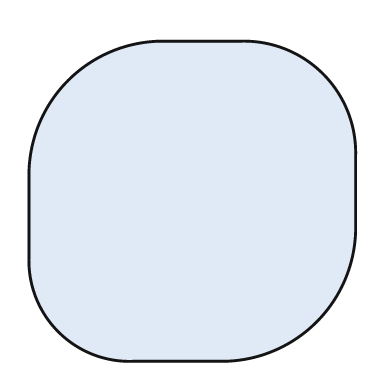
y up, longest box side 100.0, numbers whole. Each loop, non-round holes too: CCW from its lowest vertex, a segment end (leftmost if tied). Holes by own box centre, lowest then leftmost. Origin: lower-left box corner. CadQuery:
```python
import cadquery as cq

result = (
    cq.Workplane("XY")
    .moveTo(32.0, 0.0)
    .lineTo(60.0, 0.0)
    .threePointArc((88.0, 12.0), (100.0, 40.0))
    .lineTo(100.0, 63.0)
    .threePointArc((90.0, 88.0), (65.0, 98.0))
    .lineTo(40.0, 98.0)
    .threePointArc((12.0, 86.0), (0.0, 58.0))
    .lineTo(0.0, 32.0)
    .threePointArc((9.0, 9.0), (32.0, 0.0))
    .close()
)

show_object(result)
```